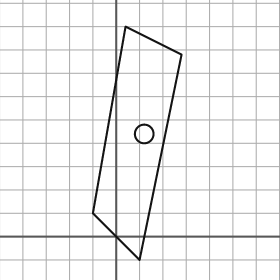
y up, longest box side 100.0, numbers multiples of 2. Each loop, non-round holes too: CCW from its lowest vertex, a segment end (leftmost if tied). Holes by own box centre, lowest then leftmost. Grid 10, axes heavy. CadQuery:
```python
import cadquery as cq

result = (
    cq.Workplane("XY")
    .moveTo(10.0, -10.0)
    .lineTo(28.0, 78.0)
    .lineTo(4.0, 90.0)
    .lineTo(-10.0, 10.0)
    .close()
    .moveTo(12.0, 44.0)
    .circle(4.0)
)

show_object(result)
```